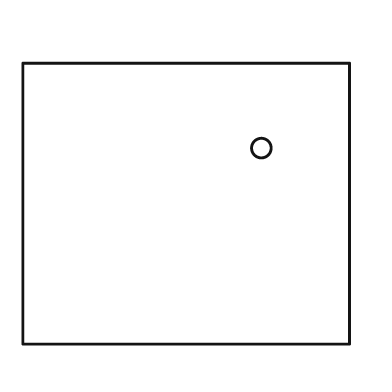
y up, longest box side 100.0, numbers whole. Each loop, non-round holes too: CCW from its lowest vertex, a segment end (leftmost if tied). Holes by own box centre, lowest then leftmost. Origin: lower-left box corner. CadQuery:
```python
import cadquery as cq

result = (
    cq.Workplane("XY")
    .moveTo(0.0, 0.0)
    .lineTo(100.0, 0.0)
    .lineTo(100.0, 86.0)
    .lineTo(0.0, 86.0)
    .close()
    .moveTo(73.0, 60.0)
    .circle(3.0)
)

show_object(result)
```